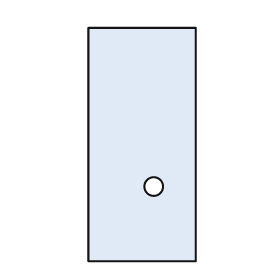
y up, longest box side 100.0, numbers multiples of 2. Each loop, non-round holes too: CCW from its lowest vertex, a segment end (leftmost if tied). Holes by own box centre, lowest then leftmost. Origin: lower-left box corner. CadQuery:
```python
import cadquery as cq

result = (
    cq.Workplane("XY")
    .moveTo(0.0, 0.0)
    .lineTo(46.0, 0.0)
    .lineTo(46.0, 100.0)
    .lineTo(0.0, 100.0)
    .close()
    .moveTo(28.0, 32.0)
    .circle(4.0)
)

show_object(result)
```